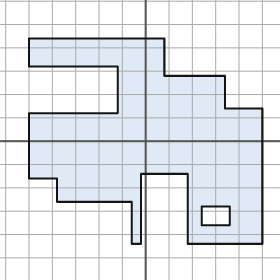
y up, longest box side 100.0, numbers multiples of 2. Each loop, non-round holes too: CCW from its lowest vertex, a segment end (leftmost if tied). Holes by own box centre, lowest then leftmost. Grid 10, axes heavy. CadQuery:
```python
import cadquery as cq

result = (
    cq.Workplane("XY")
    .moveTo(-6.0, -44.0)
    .lineTo(-2.0, -44.0)
    .lineTo(-2.0, -14.0)
    .lineTo(18.0, -14.0)
    .lineTo(18.0, -44.0)
    .lineTo(50.0, -44.0)
    .lineTo(50.0, 14.0)
    .lineTo(34.0, 14.0)
    .lineTo(34.0, 28.0)
    .lineTo(8.0, 28.0)
    .lineTo(8.0, 44.0)
    .lineTo(-50.0, 44.0)
    .lineTo(-50.0, 32.0)
    .lineTo(-12.0, 32.0)
    .lineTo(-12.0, 12.0)
    .lineTo(-50.0, 12.0)
    .lineTo(-50.0, -16.0)
    .lineTo(-38.0, -16.0)
    .lineTo(-38.0, -26.0)
    .lineTo(-6.0, -26.0)
    .close()
    .moveTo(24.0, -36.0)
    .lineTo(36.0, -36.0)
    .lineTo(36.0, -28.0)
    .lineTo(24.0, -28.0)
    .close()
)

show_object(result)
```